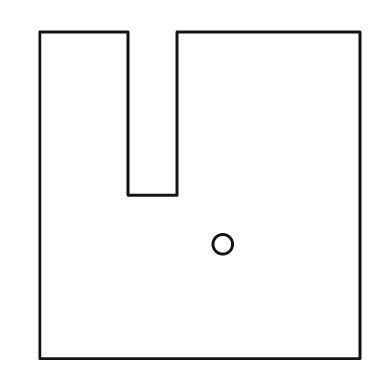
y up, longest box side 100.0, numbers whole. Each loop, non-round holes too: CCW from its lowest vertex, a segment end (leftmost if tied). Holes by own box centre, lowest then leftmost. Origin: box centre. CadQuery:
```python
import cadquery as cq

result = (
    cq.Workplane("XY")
    .moveTo(-49.0, -50.0)
    .lineTo(49.0, -50.0)
    .lineTo(49.0, 50.0)
    .lineTo(-7.0, 50.0)
    .lineTo(-7.0, 0.0)
    .lineTo(-22.0, 0.0)
    .lineTo(-22.0, 50.0)
    .lineTo(-49.0, 50.0)
    .close()
    .moveTo(7.0, -15.0)
    .circle(3.0)
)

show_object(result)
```